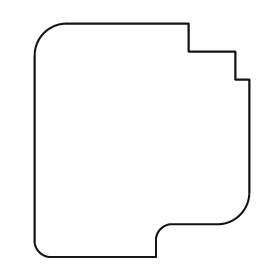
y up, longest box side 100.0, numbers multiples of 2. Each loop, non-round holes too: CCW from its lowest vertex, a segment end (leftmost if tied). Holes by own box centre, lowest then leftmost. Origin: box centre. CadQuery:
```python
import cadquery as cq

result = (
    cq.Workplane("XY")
    .moveTo(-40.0, -50.0)
    .lineTo(6.0, -50.0)
    .lineTo(6.0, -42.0)
    .threePointArc((8.0, -38.0), (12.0, -36.0))
    .lineTo(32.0, -36.0)
    .threePointArc((42.0, -32.0), (46.0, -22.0))
    .lineTo(46.0, 26.0)
    .lineTo(40.0, 26.0)
    .lineTo(40.0, 38.0)
    .lineTo(20.0, 38.0)
    .lineTo(20.0, 50.0)
    .lineTo(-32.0, 50.0)
    .threePointArc((-42.0, 46.0), (-46.0, 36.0))
    .lineTo(-46.0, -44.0)
    .threePointArc((-44.0, -48.0), (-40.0, -50.0))
    .close()
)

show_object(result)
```